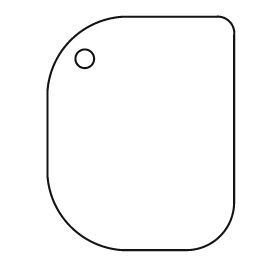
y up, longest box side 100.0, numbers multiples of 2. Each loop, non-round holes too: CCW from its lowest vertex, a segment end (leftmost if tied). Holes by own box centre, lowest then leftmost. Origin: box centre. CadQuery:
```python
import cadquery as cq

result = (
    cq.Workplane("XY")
    .moveTo(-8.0, -50.0)
    .lineTo(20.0, -50.0)
    .threePointArc((34.0, -44.0), (40.0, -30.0))
    .lineTo(40.0, 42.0)
    .threePointArc((38.0, 48.0), (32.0, 50.0))
    .lineTo(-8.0, 50.0)
    .threePointArc((-30.0, 40.0), (-40.0, 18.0))
    .lineTo(-40.0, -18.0)
    .threePointArc((-30.0, -40.0), (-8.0, -50.0))
    .close()
    .moveTo(-24.0, 32.0)
    .circle(4.0)
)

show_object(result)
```